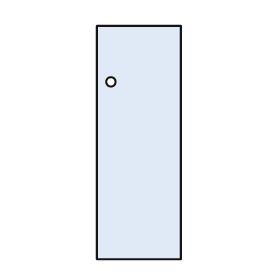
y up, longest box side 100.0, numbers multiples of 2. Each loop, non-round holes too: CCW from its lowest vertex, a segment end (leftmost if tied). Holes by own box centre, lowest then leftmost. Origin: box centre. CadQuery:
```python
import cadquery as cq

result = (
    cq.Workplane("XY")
    .moveTo(-18.0, -50.0)
    .lineTo(18.0, -50.0)
    .lineTo(18.0, 50.0)
    .lineTo(-18.0, 50.0)
    .close()
    .moveTo(-12.0, 26.0)
    .circle(2.0)
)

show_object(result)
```